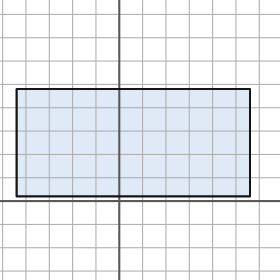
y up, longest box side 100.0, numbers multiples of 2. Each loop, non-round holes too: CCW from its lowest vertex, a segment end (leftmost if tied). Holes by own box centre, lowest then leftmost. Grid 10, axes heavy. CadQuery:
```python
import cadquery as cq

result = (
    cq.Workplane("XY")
    .moveTo(-44.0, 2.0)
    .lineTo(56.0, 2.0)
    .lineTo(56.0, 48.0)
    .lineTo(-44.0, 48.0)
    .close()
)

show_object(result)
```